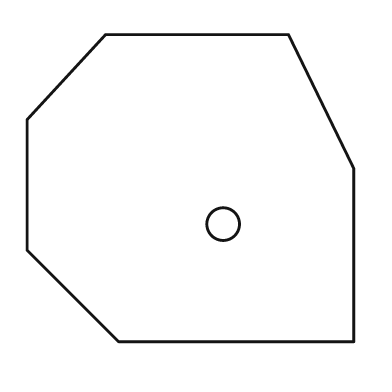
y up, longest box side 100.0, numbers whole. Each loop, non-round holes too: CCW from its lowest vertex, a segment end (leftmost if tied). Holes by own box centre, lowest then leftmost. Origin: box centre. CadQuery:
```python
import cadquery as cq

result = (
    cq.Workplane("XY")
    .moveTo(-22.0, -47.0)
    .lineTo(50.0, -47.0)
    .lineTo(50.0, 6.0)
    .lineTo(30.0, 47.0)
    .lineTo(-26.0, 47.0)
    .lineTo(-50.0, 21.0)
    .lineTo(-50.0, -19.0)
    .close()
    .moveTo(10.0, -11.0)
    .circle(5.0)
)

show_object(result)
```